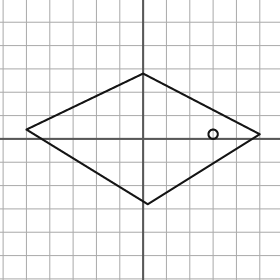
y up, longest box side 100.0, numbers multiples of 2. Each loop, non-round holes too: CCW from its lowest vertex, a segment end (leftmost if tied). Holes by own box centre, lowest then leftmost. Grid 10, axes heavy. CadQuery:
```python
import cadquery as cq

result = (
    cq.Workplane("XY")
    .moveTo(2.0, -28.0)
    .lineTo(50.0, 2.0)
    .lineTo(0.0, 28.0)
    .lineTo(-50.0, 4.0)
    .close()
    .moveTo(30.0, 2.0)
    .circle(2.0)
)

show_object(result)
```